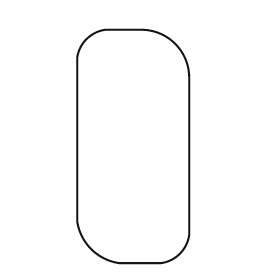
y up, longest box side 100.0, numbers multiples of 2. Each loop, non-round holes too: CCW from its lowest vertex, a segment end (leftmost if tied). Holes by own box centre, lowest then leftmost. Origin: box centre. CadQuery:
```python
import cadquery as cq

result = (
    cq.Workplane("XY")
    .moveTo(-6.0, -50.0)
    .lineTo(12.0, -50.0)
    .threePointArc((20.0, -46.0), (24.0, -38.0))
    .lineTo(24.0, 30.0)
    .threePointArc((18.0, 44.0), (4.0, 50.0))
    .lineTo(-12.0, 50.0)
    .threePointArc((-20.0, 46.0), (-24.0, 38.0))
    .lineTo(-24.0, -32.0)
    .threePointArc((-18.0, -44.0), (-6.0, -50.0))
    .close()
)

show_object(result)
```